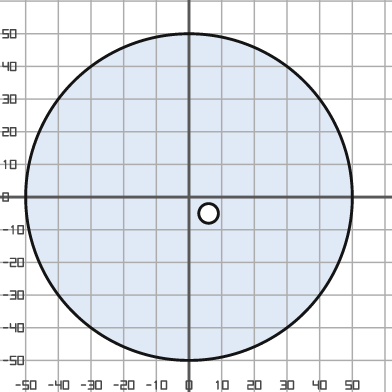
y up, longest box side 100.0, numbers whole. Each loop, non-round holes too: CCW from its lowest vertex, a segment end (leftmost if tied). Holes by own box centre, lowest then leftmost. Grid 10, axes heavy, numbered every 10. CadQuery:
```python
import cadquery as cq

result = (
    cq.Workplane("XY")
    .moveTo(0.0, 0.0)
    .circle(50.0)
    .moveTo(6.0, -5.0)
    .circle(3.0)
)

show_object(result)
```